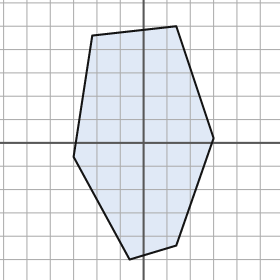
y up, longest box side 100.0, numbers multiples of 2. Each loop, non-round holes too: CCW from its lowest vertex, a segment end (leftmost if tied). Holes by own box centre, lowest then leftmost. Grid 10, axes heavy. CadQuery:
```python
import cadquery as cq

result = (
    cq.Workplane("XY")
    .moveTo(-6.0, -50.0)
    .lineTo(14.0, -44.0)
    .lineTo(30.0, 2.0)
    .lineTo(14.0, 50.0)
    .lineTo(-22.0, 46.0)
    .lineTo(-30.0, -6.0)
    .close()
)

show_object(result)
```